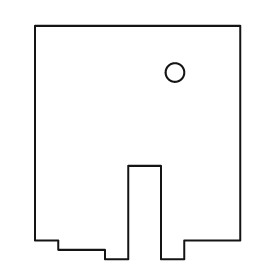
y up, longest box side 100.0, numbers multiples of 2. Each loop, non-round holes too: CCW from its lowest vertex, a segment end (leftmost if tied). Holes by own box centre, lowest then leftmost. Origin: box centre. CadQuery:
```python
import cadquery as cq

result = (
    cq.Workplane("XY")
    .moveTo(-14.0, -50.0)
    .lineTo(-4.0, -50.0)
    .lineTo(-4.0, -10.0)
    .lineTo(10.0, -10.0)
    .lineTo(10.0, -50.0)
    .lineTo(20.0, -50.0)
    .lineTo(20.0, -42.0)
    .lineTo(44.0, -42.0)
    .lineTo(44.0, 50.0)
    .lineTo(-44.0, 50.0)
    .lineTo(-44.0, -42.0)
    .lineTo(-34.0, -42.0)
    .lineTo(-34.0, -46.0)
    .lineTo(-14.0, -46.0)
    .close()
    .moveTo(16.0, 30.0)
    .circle(4.0)
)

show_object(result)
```